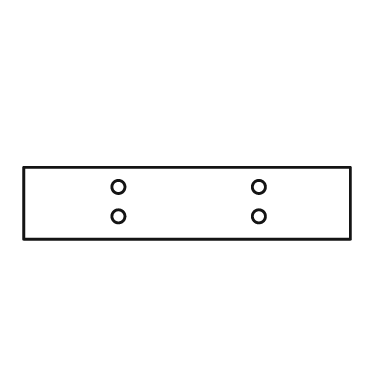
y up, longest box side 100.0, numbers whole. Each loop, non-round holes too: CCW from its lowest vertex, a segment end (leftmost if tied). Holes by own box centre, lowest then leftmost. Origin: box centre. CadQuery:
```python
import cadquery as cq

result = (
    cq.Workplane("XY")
    .moveTo(-50.0, -11.0)
    .lineTo(50.0, -11.0)
    .lineTo(50.0, 11.0)
    .lineTo(-50.0, 11.0)
    .close()
    .moveTo(-21.0, -4.0)
    .circle(2.0)
    .moveTo(22.0, -4.0)
    .circle(2.0)
    .moveTo(-21.0, 5.0)
    .circle(2.0)
    .moveTo(22.0, 5.0)
    .circle(2.0)
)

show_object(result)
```